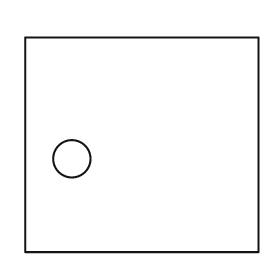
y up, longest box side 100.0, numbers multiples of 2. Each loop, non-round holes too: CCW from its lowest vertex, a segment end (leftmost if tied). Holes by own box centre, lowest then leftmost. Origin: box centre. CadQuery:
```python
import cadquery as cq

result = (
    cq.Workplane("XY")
    .moveTo(-50.0, -46.0)
    .lineTo(50.0, -46.0)
    .lineTo(50.0, 46.0)
    .lineTo(-50.0, 46.0)
    .close()
    .moveTo(-30.0, -6.0)
    .circle(8.0)
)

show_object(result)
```